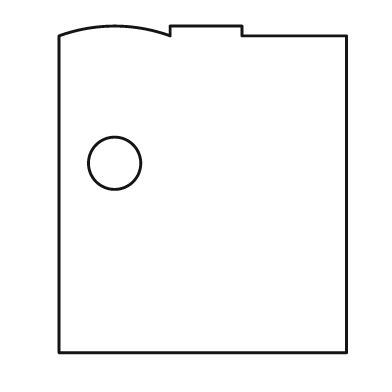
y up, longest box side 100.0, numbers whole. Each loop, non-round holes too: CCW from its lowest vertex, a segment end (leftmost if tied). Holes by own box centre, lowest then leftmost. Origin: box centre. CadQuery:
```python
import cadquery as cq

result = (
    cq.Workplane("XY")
    .moveTo(-44.0, -50.0)
    .lineTo(44.0, -50.0)
    .lineTo(44.0, 47.0)
    .lineTo(12.0, 47.0)
    .lineTo(12.0, 50.0)
    .lineTo(-10.0, 50.0)
    .lineTo(-10.0, 47.0)
    .threePointArc((-27.0, 50.0), (-44.0, 47.0))
    .close()
    .moveTo(-27.0, 8.0)
    .circle(8.0)
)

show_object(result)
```